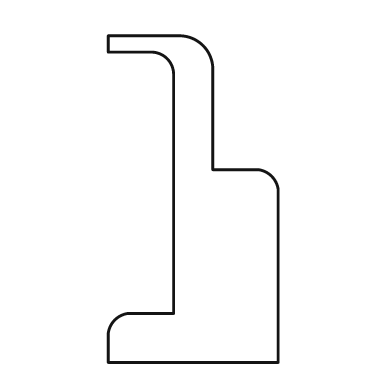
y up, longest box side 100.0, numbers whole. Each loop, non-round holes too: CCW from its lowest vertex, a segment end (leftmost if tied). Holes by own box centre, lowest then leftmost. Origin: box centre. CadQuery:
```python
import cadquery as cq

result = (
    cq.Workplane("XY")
    .moveTo(-26.0, -50.0)
    .lineTo(26.0, -50.0)
    .lineTo(26.0, 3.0)
    .threePointArc((24.0, 7.0), (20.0, 9.0))
    .lineTo(6.0, 9.0)
    .lineTo(6.0, 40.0)
    .threePointArc((3.0, 47.0), (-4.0, 50.0))
    .lineTo(-26.0, 50.0)
    .lineTo(-26.0, 45.0)
    .lineTo(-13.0, 45.0)
    .threePointArc((-8.0, 43.0), (-6.0, 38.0))
    .lineTo(-6.0, -35.0)
    .lineTo(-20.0, -35.0)
    .threePointArc((-24.0, -37.0), (-26.0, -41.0))
    .close()
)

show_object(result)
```